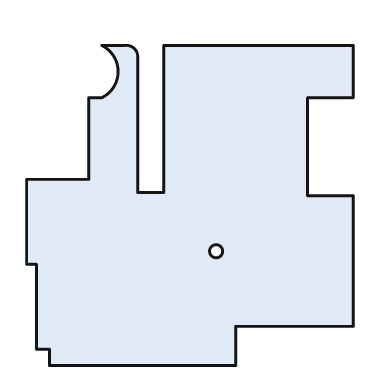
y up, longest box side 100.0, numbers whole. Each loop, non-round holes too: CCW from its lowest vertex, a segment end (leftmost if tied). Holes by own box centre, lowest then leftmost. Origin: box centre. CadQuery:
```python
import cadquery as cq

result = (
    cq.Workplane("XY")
    .moveTo(-43.0, -49.0)
    .lineTo(14.0, -49.0)
    .lineTo(14.0, -37.0)
    .lineTo(50.0, -37.0)
    .lineTo(50.0, 3.0)
    .lineTo(36.0, 3.0)
    .lineTo(36.0, 33.0)
    .lineTo(50.0, 33.0)
    .lineTo(50.0, 49.0)
    .lineTo(-8.0, 49.0)
    .lineTo(-8.0, 4.0)
    .lineTo(-16.0, 4.0)
    .lineTo(-16.0, 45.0)
    .threePointArc((-17.0, 48.0), (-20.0, 49.0))
    .lineTo(-27.0, 49.0)
    .threePointArc((-22.0, 41.0), (-27.0, 33.0))
    .lineTo(-31.0, 33.0)
    .lineTo(-31.0, 8.0)
    .lineTo(-50.0, 8.0)
    .lineTo(-50.0, -18.0)
    .lineTo(-47.0, -18.0)
    .lineTo(-47.0, -44.0)
    .lineTo(-43.0, -44.0)
    .close()
    .moveTo(8.0, -14.0)
    .circle(2.0)
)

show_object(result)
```